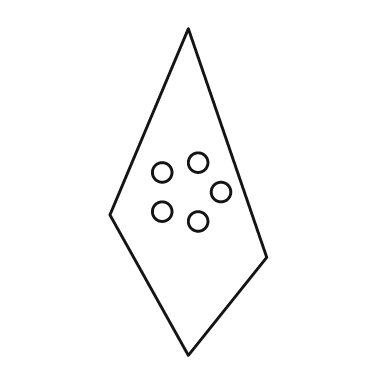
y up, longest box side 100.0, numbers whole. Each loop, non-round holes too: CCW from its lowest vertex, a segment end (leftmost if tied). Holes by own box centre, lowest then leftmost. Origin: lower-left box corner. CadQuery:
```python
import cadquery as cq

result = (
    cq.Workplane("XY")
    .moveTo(24.0, 0.0)
    .lineTo(48.0, 30.0)
    .lineTo(24.0, 100.0)
    .lineTo(0.0, 43.0)
    .close()
    .moveTo(27.0, 41.0)
    .circle(3.0)
    .moveTo(16.0, 44.0)
    .circle(3.0)
    .moveTo(34.0, 50.0)
    .circle(3.0)
    .moveTo(16.0, 56.0)
    .circle(3.0)
    .moveTo(27.0, 59.0)
    .circle(3.0)
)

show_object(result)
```